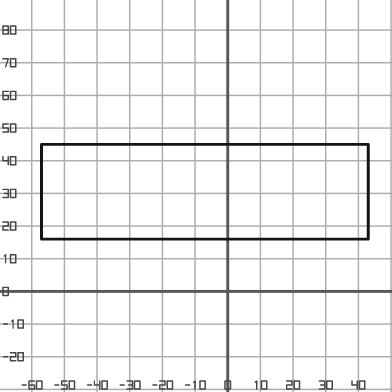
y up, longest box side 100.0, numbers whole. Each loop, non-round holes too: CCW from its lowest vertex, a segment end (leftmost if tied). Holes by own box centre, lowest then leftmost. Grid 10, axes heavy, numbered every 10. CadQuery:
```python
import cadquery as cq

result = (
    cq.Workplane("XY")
    .moveTo(-57.0, 16.0)
    .lineTo(43.0, 16.0)
    .lineTo(43.0, 45.0)
    .lineTo(-57.0, 45.0)
    .close()
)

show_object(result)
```